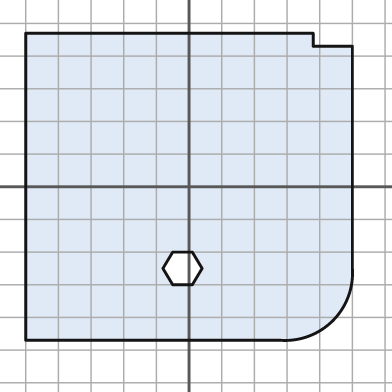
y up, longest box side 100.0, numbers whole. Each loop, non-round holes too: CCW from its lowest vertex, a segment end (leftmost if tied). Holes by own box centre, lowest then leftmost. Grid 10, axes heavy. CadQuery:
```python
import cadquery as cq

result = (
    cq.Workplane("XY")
    .moveTo(-50.0, -47.0)
    .lineTo(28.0, -47.0)
    .threePointArc((44.0, -41.0), (50.0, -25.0))
    .lineTo(50.0, 43.0)
    .lineTo(38.0, 43.0)
    .lineTo(38.0, 47.0)
    .lineTo(-50.0, 47.0)
    .close()
    .moveTo(-5.0, -30.0)
    .lineTo(1.0, -30.0)
    .lineTo(4.0, -25.0)
    .lineTo(1.0, -20.0)
    .lineTo(-5.0, -20.0)
    .lineTo(-8.0, -25.0)
    .close()
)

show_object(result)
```